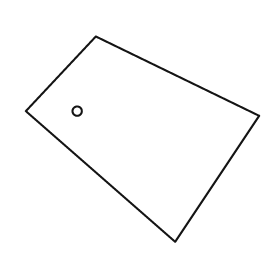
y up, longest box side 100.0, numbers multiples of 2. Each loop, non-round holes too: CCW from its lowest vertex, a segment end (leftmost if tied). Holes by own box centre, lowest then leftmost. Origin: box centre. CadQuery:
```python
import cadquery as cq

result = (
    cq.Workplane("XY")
    .moveTo(14.0, -44.0)
    .lineTo(50.0, 10.0)
    .lineTo(-20.0, 44.0)
    .lineTo(-50.0, 12.0)
    .close()
    .moveTo(-28.0, 12.0)
    .circle(2.0)
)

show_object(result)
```